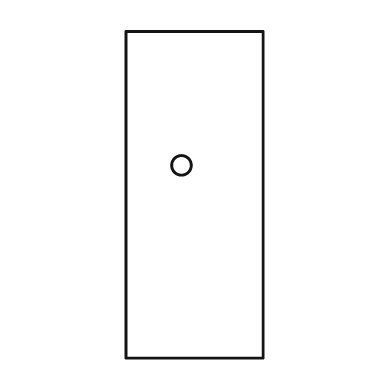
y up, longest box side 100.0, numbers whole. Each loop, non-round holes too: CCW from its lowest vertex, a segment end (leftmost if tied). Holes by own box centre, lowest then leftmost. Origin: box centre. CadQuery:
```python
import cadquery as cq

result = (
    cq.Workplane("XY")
    .moveTo(-21.0, -50.0)
    .lineTo(21.0, -50.0)
    .lineTo(21.0, 50.0)
    .lineTo(-21.0, 50.0)
    .close()
    .moveTo(-4.0, 9.0)
    .circle(3.0)
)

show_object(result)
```